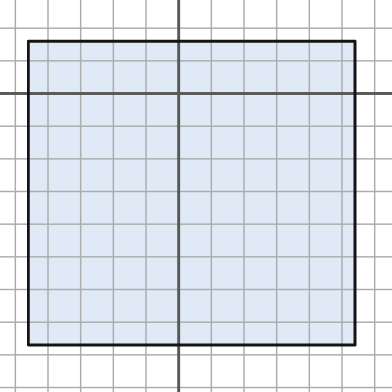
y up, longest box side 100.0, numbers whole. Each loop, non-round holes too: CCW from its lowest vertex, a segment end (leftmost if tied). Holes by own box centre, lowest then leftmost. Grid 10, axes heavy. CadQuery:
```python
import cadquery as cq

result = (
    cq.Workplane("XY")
    .moveTo(-46.0, -77.0)
    .lineTo(54.0, -77.0)
    .lineTo(54.0, 16.0)
    .lineTo(-46.0, 16.0)
    .close()
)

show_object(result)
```